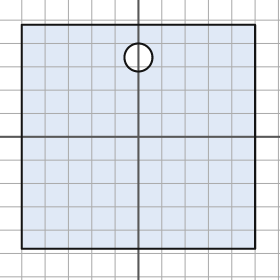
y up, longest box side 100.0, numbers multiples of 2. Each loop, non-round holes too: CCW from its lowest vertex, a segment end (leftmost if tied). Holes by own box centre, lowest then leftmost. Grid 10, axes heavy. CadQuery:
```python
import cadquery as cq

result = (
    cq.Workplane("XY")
    .moveTo(-50.0, -48.0)
    .lineTo(50.0, -48.0)
    .lineTo(50.0, 48.0)
    .lineTo(-50.0, 48.0)
    .close()
    .moveTo(0.0, 34.0)
    .circle(6.0)
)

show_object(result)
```